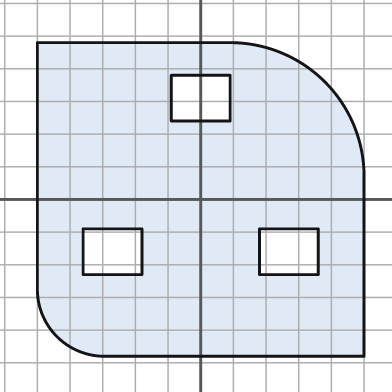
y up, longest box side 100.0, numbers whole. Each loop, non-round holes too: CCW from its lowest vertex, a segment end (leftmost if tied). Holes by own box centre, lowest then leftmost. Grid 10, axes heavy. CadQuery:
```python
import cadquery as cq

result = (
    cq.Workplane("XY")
    .moveTo(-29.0, -48.0)
    .lineTo(50.0, -48.0)
    .lineTo(50.0, 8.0)
    .threePointArc((38.0, 36.0), (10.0, 48.0))
    .lineTo(-50.0, 48.0)
    .lineTo(-50.0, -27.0)
    .threePointArc((-44.0, -42.0), (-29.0, -48.0))
    .close()
    .moveTo(-36.0, -23.0)
    .lineTo(-18.0, -23.0)
    .lineTo(-18.0, -9.0)
    .lineTo(-36.0, -9.0)
    .close()
    .moveTo(18.0, -23.0)
    .lineTo(36.0, -23.0)
    .lineTo(36.0, -9.0)
    .lineTo(18.0, -9.0)
    .close()
    .moveTo(-9.0, 24.0)
    .lineTo(9.0, 24.0)
    .lineTo(9.0, 38.0)
    .lineTo(-9.0, 38.0)
    .close()
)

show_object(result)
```